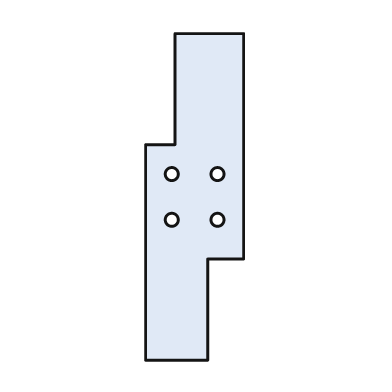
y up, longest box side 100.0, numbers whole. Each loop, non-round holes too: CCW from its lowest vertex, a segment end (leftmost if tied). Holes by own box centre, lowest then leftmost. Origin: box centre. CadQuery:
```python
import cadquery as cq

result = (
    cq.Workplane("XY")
    .moveTo(-15.0, -50.0)
    .lineTo(4.0, -50.0)
    .lineTo(4.0, -19.0)
    .lineTo(15.0, -19.0)
    .lineTo(15.0, 50.0)
    .lineTo(-6.0, 50.0)
    .lineTo(-6.0, 16.0)
    .lineTo(-15.0, 16.0)
    .close()
    .moveTo(-7.0, -7.0)
    .circle(2.0)
    .moveTo(7.0, -7.0)
    .circle(2.0)
    .moveTo(-7.0, 7.0)
    .circle(2.0)
    .moveTo(7.0, 7.0)
    .circle(2.0)
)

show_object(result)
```